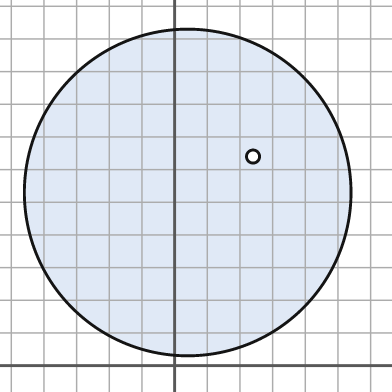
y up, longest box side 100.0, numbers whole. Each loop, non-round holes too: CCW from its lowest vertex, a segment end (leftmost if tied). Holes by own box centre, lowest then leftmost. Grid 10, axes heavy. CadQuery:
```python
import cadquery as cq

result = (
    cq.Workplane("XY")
    .moveTo(4.0, 53.0)
    .circle(50.0)
    .moveTo(24.0, 64.0)
    .circle(2.0)
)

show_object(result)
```